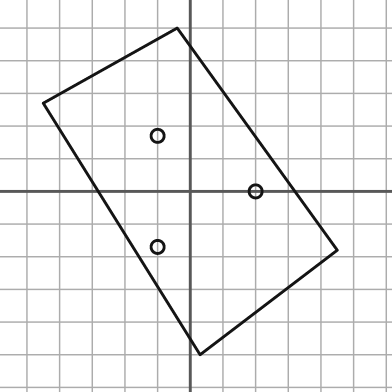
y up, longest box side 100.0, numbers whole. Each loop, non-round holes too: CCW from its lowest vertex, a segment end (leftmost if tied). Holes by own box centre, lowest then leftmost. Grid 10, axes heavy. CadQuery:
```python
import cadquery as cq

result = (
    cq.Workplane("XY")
    .moveTo(3.0, -50.0)
    .lineTo(45.0, -18.0)
    .lineTo(-4.0, 50.0)
    .lineTo(-45.0, 27.0)
    .close()
    .moveTo(-10.0, -17.0)
    .circle(2.0)
    .moveTo(20.0, 0.0)
    .circle(2.0)
    .moveTo(-10.0, 17.0)
    .circle(2.0)
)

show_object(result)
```